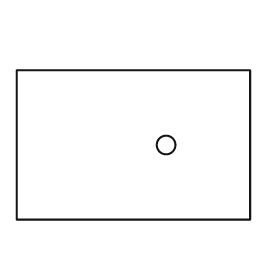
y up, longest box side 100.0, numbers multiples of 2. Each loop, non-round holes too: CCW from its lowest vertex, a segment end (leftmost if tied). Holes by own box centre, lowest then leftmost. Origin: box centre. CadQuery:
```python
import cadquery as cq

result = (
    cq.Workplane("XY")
    .moveTo(-50.0, -32.0)
    .lineTo(50.0, -32.0)
    .lineTo(50.0, 32.0)
    .lineTo(-50.0, 32.0)
    .close()
    .moveTo(14.0, 0.0)
    .circle(4.0)
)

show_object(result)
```